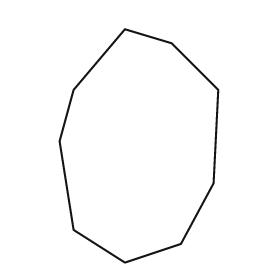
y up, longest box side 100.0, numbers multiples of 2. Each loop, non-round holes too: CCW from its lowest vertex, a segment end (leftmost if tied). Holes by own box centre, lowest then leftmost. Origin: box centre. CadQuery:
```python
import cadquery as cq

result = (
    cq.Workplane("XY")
    .moveTo(-6.0, -50.0)
    .lineTo(18.0, -42.0)
    .lineTo(32.0, -16.0)
    .lineTo(34.0, 24.0)
    .lineTo(14.0, 44.0)
    .lineTo(-6.0, 50.0)
    .lineTo(-28.0, 24.0)
    .lineTo(-34.0, 2.0)
    .lineTo(-28.0, -36.0)
    .close()
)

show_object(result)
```